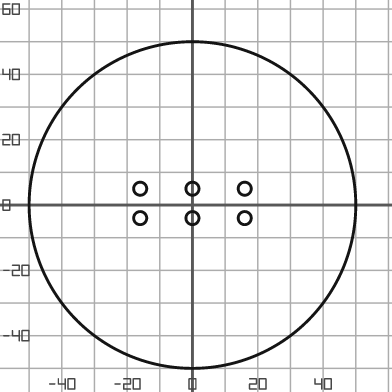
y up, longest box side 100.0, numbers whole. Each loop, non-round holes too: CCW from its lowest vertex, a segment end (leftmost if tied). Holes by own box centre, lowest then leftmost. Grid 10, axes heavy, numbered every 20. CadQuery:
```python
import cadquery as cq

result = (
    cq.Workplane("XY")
    .moveTo(0.0, 0.0)
    .circle(50.0)
    .moveTo(-16.0, -4.0)
    .circle(2.0)
    .moveTo(0.0, -4.0)
    .circle(2.0)
    .moveTo(16.0, -4.0)
    .circle(2.0)
    .moveTo(-16.0, 5.0)
    .circle(2.0)
    .moveTo(0.0, 5.0)
    .circle(2.0)
    .moveTo(16.0, 5.0)
    .circle(2.0)
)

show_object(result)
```